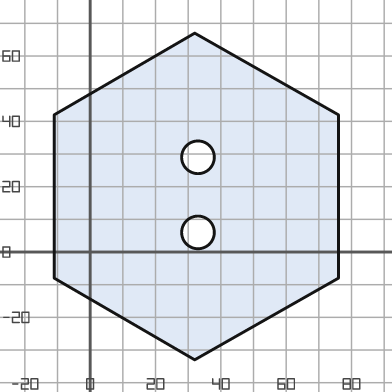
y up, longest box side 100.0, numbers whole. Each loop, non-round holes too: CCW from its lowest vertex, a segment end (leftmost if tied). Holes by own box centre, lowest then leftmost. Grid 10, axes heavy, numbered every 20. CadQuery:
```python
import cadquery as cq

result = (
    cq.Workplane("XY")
    .moveTo(32.0, -33.0)
    .lineTo(76.0, -8.0)
    .lineTo(76.0, 42.0)
    .lineTo(32.0, 67.0)
    .lineTo(-11.0, 42.0)
    .lineTo(-11.0, -8.0)
    .close()
    .moveTo(33.0, 6.0)
    .circle(5.0)
    .moveTo(33.0, 29.0)
    .circle(5.0)
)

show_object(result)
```